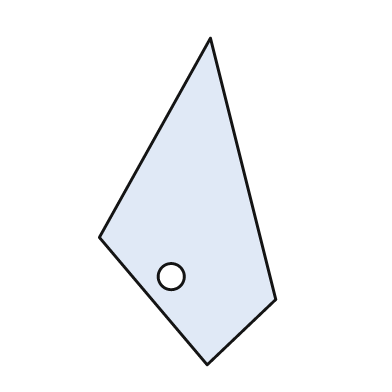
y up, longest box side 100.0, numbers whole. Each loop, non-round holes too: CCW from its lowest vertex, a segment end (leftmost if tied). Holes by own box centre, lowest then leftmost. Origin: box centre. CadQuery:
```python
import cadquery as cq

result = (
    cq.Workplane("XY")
    .moveTo(6.0, -50.0)
    .lineTo(27.0, -30.0)
    .lineTo(7.0, 50.0)
    .lineTo(-27.0, -11.0)
    .close()
    .moveTo(-5.0, -23.0)
    .circle(4.0)
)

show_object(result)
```